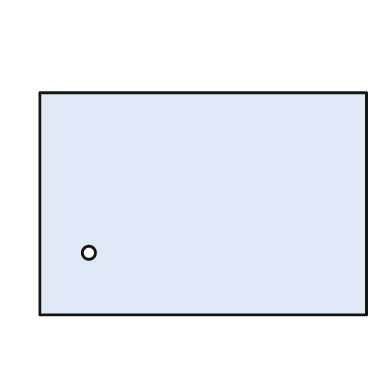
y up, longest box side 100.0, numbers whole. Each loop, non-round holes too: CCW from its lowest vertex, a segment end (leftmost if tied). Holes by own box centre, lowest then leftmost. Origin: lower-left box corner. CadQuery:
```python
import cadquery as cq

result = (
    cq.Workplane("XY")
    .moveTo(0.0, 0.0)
    .lineTo(100.0, 0.0)
    .lineTo(100.0, 68.0)
    .lineTo(0.0, 68.0)
    .close()
    .moveTo(15.0, 19.0)
    .circle(2.0)
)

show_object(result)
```